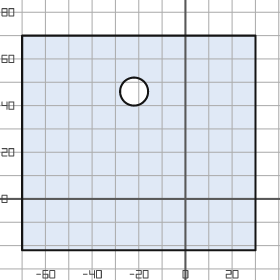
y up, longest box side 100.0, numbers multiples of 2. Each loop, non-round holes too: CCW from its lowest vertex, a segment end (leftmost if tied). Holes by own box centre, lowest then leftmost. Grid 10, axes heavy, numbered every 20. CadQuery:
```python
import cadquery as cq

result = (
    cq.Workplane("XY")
    .moveTo(-70.0, -22.0)
    .lineTo(30.0, -22.0)
    .lineTo(30.0, 70.0)
    .lineTo(-70.0, 70.0)
    .close()
    .moveTo(-22.0, 46.0)
    .circle(6.0)
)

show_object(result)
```